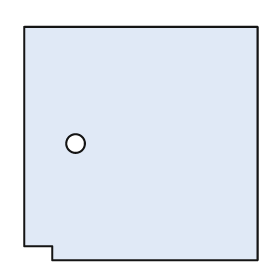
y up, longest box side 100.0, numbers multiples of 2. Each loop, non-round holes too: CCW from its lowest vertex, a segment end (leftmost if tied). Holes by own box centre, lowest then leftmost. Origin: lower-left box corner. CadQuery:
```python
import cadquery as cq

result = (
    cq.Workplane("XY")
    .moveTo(12.0, 0.0)
    .lineTo(100.0, 0.0)
    .lineTo(100.0, 100.0)
    .lineTo(0.0, 100.0)
    .lineTo(0.0, 6.0)
    .lineTo(12.0, 6.0)
    .close()
    .moveTo(22.0, 50.0)
    .circle(4.0)
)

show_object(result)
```